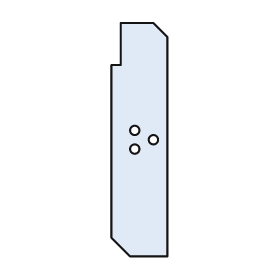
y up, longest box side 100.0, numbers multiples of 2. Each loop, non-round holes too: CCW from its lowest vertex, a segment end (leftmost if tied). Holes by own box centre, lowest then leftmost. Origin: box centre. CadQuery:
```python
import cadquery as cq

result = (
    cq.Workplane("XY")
    .moveTo(-4.0, -50.0)
    .lineTo(12.0, -50.0)
    .lineTo(12.0, 44.0)
    .lineTo(6.0, 50.0)
    .lineTo(-8.0, 50.0)
    .lineTo(-8.0, 32.0)
    .lineTo(-12.0, 32.0)
    .lineTo(-12.0, -42.0)
    .close()
    .moveTo(-2.0, -4.0)
    .circle(2.0)
    .moveTo(6.0, 0.0)
    .circle(2.0)
    .moveTo(-2.0, 4.0)
    .circle(2.0)
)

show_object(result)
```